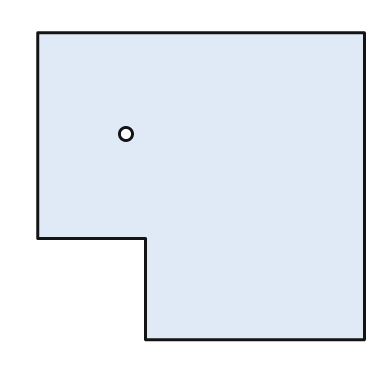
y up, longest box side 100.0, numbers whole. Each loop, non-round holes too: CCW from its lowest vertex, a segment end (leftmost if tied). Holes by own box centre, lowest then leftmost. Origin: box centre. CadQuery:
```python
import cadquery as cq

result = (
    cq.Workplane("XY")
    .moveTo(-17.0, -47.0)
    .lineTo(50.0, -47.0)
    .lineTo(50.0, 47.0)
    .lineTo(-50.0, 47.0)
    .lineTo(-50.0, -16.0)
    .lineTo(-17.0, -16.0)
    .close()
    .moveTo(-23.0, 16.0)
    .circle(2.0)
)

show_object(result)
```